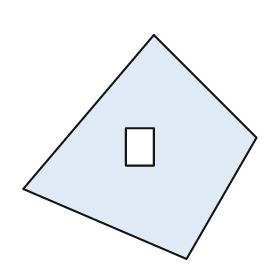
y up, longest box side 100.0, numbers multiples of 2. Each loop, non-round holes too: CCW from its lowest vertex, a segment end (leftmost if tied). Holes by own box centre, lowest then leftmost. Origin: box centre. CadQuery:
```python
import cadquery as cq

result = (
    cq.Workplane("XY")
    .moveTo(20.0, -48.0)
    .lineTo(50.0, 4.0)
    .lineTo(6.0, 48.0)
    .lineTo(-50.0, -18.0)
    .close()
    .moveTo(-6.0, -8.0)
    .lineTo(6.0, -8.0)
    .lineTo(6.0, 8.0)
    .lineTo(-6.0, 8.0)
    .close()
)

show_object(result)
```